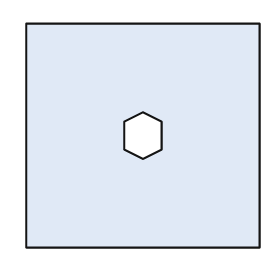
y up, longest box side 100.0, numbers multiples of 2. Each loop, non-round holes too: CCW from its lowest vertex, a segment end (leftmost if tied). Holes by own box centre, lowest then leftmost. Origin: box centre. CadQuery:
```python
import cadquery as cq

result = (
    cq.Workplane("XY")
    .moveTo(-50.0, -48.0)
    .lineTo(50.0, -48.0)
    .lineTo(50.0, 48.0)
    .lineTo(-50.0, 48.0)
    .close()
    .moveTo(0.0, -10.0)
    .lineTo(8.0, -6.0)
    .lineTo(8.0, 6.0)
    .lineTo(0.0, 10.0)
    .lineTo(-8.0, 6.0)
    .lineTo(-8.0, -6.0)
    .close()
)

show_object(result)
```